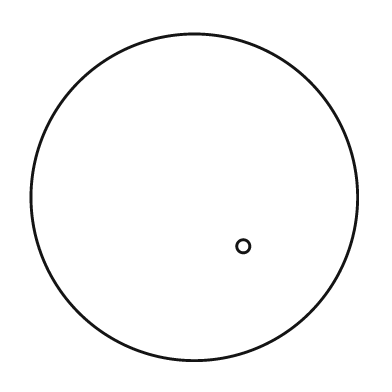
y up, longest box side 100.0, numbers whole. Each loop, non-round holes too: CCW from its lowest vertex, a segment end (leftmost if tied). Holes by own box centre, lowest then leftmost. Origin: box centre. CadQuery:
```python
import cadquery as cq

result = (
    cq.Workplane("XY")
    .moveTo(0.0, 0.0)
    .circle(50.0)
    .moveTo(15.0, -15.0)
    .circle(2.0)
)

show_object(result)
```